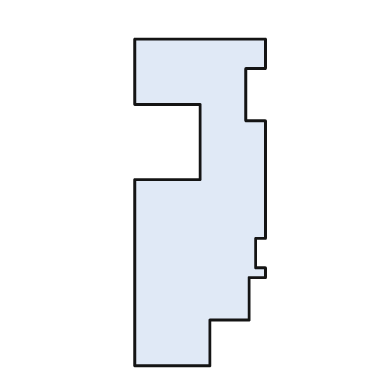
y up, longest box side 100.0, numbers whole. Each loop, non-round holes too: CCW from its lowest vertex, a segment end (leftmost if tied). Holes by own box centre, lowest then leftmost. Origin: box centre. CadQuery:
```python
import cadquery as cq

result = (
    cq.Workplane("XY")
    .moveTo(-20.0, -50.0)
    .lineTo(3.0, -50.0)
    .lineTo(3.0, -36.0)
    .lineTo(15.0, -36.0)
    .lineTo(15.0, -23.0)
    .lineTo(20.0, -23.0)
    .lineTo(20.0, -20.0)
    .lineTo(17.0, -20.0)
    .lineTo(17.0, -11.0)
    .lineTo(20.0, -11.0)
    .lineTo(20.0, 25.0)
    .lineTo(14.0, 25.0)
    .lineTo(14.0, 41.0)
    .lineTo(20.0, 41.0)
    .lineTo(20.0, 50.0)
    .lineTo(-20.0, 50.0)
    .lineTo(-20.0, 30.0)
    .lineTo(0.0, 30.0)
    .lineTo(0.0, 7.0)
    .lineTo(-20.0, 7.0)
    .close()
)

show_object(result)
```